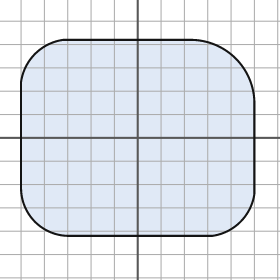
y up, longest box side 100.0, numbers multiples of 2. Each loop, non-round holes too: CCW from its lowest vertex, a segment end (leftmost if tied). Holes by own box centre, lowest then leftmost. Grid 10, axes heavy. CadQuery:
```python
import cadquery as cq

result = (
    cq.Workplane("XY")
    .moveTo(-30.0, -42.0)
    .lineTo(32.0, -42.0)
    .threePointArc((44.0, -36.0), (50.0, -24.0))
    .lineTo(50.0, 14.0)
    .threePointArc((42.0, 34.0), (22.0, 42.0))
    .lineTo(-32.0, 42.0)
    .threePointArc((-44.0, 36.0), (-50.0, 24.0))
    .lineTo(-50.0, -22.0)
    .threePointArc((-44.0, -36.0), (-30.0, -42.0))
    .close()
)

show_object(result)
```